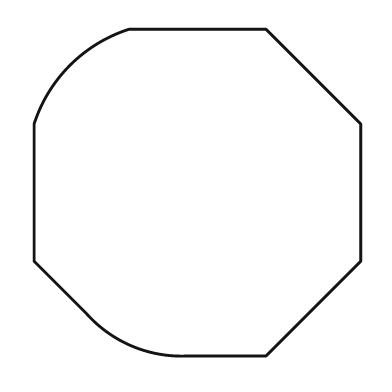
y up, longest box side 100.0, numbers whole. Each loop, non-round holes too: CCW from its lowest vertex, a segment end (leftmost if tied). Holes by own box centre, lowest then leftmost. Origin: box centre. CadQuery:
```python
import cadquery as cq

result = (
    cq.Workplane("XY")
    .moveTo(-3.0, -50.0)
    .lineTo(21.0, -50.0)
    .lineTo(50.0, -21.0)
    .lineTo(50.0, 21.0)
    .lineTo(21.0, 50.0)
    .lineTo(-21.0, 50.0)
    .threePointArc((-39.0, 39.0), (-50.0, 21.0))
    .lineTo(-50.0, -21.0)
    .lineTo(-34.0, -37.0)
    .threePointArc((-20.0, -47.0), (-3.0, -50.0))
    .close()
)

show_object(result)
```